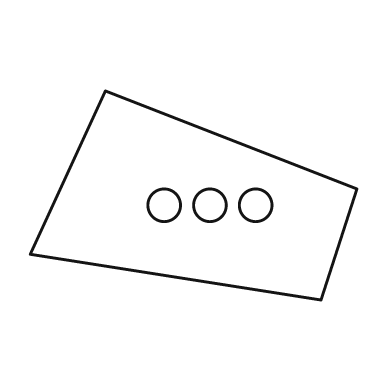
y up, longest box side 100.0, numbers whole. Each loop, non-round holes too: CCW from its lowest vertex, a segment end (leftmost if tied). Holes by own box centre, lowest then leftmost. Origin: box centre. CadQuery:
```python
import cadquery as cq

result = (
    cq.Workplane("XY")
    .moveTo(39.0, -32.0)
    .lineTo(50.0, 2.0)
    .lineTo(-27.0, 32.0)
    .lineTo(-50.0, -18.0)
    .close()
    .moveTo(-9.0, -3.0)
    .circle(5.0)
    .moveTo(5.0, -3.0)
    .circle(5.0)
    .moveTo(19.0, -3.0)
    .circle(5.0)
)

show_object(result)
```